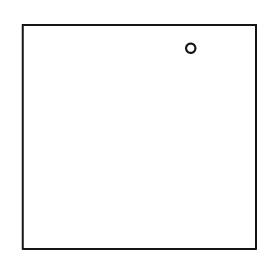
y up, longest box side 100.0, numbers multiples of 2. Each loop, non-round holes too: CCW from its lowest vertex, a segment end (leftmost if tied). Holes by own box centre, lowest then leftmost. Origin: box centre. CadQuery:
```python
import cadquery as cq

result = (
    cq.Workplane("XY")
    .moveTo(-50.0, -48.0)
    .lineTo(50.0, -48.0)
    .lineTo(50.0, 48.0)
    .lineTo(-50.0, 48.0)
    .close()
    .moveTo(22.0, 38.0)
    .circle(2.0)
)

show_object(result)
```